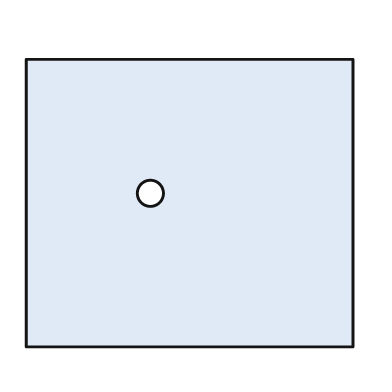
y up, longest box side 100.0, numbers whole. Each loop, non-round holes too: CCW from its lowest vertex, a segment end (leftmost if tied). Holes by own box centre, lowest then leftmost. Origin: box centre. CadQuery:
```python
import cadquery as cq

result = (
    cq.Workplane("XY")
    .moveTo(-50.0, -44.0)
    .lineTo(50.0, -44.0)
    .lineTo(50.0, 44.0)
    .lineTo(-50.0, 44.0)
    .close()
    .moveTo(-12.0, 3.0)
    .circle(4.0)
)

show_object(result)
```